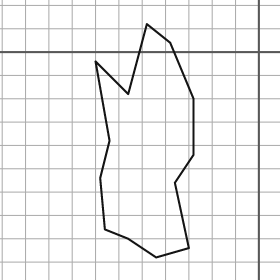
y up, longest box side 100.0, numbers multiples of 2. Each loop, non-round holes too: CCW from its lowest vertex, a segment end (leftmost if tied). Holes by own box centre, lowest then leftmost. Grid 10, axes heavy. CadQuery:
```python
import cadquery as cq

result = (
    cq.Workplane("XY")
    .moveTo(-44.0, -88.0)
    .lineTo(-30.0, -84.0)
    .lineTo(-36.0, -56.0)
    .lineTo(-28.0, -44.0)
    .lineTo(-28.0, -20.0)
    .lineTo(-38.0, 4.0)
    .lineTo(-48.0, 12.0)
    .lineTo(-56.0, -18.0)
    .lineTo(-70.0, -4.0)
    .lineTo(-64.0, -38.0)
    .lineTo(-68.0, -54.0)
    .lineTo(-66.0, -76.0)
    .lineTo(-56.0, -80.0)
    .close()
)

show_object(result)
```